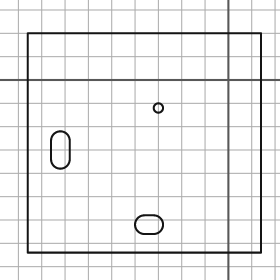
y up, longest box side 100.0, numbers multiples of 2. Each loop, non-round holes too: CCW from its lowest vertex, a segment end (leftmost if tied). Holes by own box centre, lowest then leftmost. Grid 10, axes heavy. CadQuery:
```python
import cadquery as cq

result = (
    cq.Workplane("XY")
    .moveTo(-86.0, -74.0)
    .lineTo(14.0, -74.0)
    .lineTo(14.0, 20.0)
    .lineTo(-86.0, 20.0)
    .close()
    .moveTo(-36.0, -66.0)
    .lineTo(-32.0, -66.0)
    .threePointArc((-28.0, -62.0), (-32.0, -58.0))
    .lineTo(-36.0, -58.0)
    .threePointArc((-40.0, -62.0), (-36.0, -66.0))
    .close()
    .moveTo(-76.0, -34.0)
    .threePointArc((-72.0, -38.0), (-68.0, -34.0))
    .lineTo(-68.0, -26.0)
    .threePointArc((-72.0, -22.0), (-76.0, -26.0))
    .close()
    .moveTo(-30.0, -12.0)
    .circle(2.0)
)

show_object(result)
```